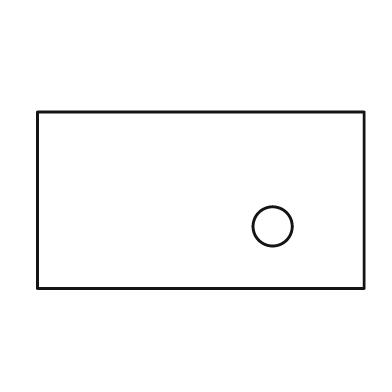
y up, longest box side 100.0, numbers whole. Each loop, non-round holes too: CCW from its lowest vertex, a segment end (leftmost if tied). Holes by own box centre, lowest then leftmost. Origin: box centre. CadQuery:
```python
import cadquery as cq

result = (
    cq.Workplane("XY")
    .moveTo(-50.0, -27.0)
    .lineTo(50.0, -27.0)
    .lineTo(50.0, 27.0)
    .lineTo(-50.0, 27.0)
    .close()
    .moveTo(22.0, -8.0)
    .circle(6.0)
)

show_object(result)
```